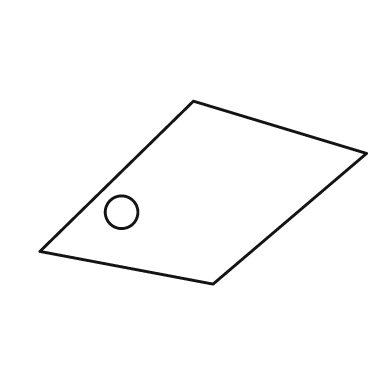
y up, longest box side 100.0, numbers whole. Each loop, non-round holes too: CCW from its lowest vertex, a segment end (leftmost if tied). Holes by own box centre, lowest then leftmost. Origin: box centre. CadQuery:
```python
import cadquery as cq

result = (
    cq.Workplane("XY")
    .moveTo(3.0, -28.0)
    .lineTo(50.0, 12.0)
    .lineTo(-3.0, 28.0)
    .lineTo(-50.0, -18.0)
    .close()
    .moveTo(-25.0, -6.0)
    .circle(5.0)
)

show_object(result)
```